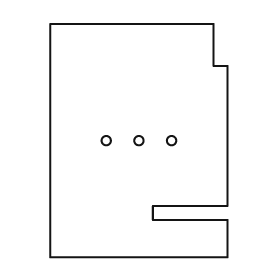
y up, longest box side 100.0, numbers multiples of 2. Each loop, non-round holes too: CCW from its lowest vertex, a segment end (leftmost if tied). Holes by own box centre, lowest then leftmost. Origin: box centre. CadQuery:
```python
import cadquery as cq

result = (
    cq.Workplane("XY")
    .moveTo(-38.0, -50.0)
    .lineTo(38.0, -50.0)
    .lineTo(38.0, -34.0)
    .lineTo(6.0, -34.0)
    .lineTo(6.0, -28.0)
    .lineTo(38.0, -28.0)
    .lineTo(38.0, 32.0)
    .lineTo(32.0, 32.0)
    .lineTo(32.0, 50.0)
    .lineTo(-38.0, 50.0)
    .close()
    .moveTo(-14.0, 0.0)
    .circle(2.0)
    .moveTo(0.0, 0.0)
    .circle(2.0)
    .moveTo(14.0, 0.0)
    .circle(2.0)
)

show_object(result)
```